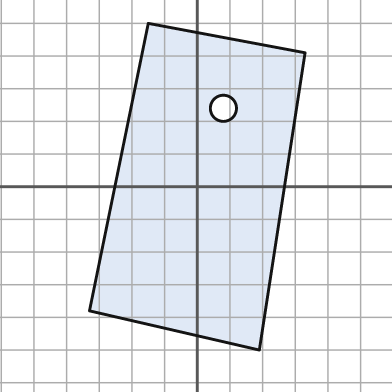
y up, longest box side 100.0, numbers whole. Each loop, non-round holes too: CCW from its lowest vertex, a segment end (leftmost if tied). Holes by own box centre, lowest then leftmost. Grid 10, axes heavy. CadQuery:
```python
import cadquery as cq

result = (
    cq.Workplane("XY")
    .moveTo(19.0, -50.0)
    .lineTo(33.0, 41.0)
    .lineTo(-15.0, 50.0)
    .lineTo(-33.0, -38.0)
    .close()
    .moveTo(8.0, 24.0)
    .circle(4.0)
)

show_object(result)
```